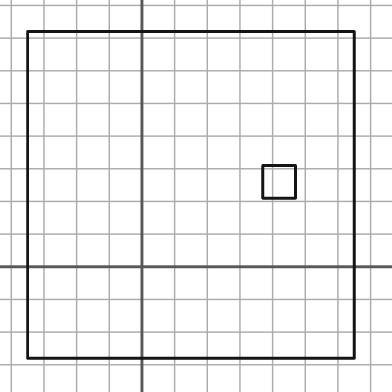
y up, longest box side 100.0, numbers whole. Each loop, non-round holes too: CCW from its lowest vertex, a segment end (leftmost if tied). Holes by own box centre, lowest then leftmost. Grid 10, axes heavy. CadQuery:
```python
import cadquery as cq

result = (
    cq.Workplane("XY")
    .moveTo(-35.0, -28.0)
    .lineTo(65.0, -28.0)
    .lineTo(65.0, 72.0)
    .lineTo(-35.0, 72.0)
    .close()
    .moveTo(37.0, 21.0)
    .lineTo(47.0, 21.0)
    .lineTo(47.0, 31.0)
    .lineTo(37.0, 31.0)
    .close()
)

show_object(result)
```